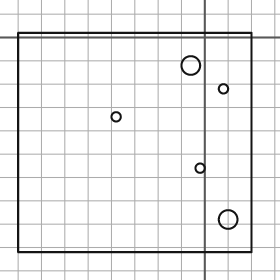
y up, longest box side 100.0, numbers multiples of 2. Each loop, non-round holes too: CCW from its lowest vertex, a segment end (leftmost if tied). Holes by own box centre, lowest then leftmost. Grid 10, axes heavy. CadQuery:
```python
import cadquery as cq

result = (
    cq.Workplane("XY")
    .moveTo(-80.0, -92.0)
    .lineTo(20.0, -92.0)
    .lineTo(20.0, 2.0)
    .lineTo(-80.0, 2.0)
    .close()
    .moveTo(10.0, -78.0)
    .circle(4.0)
    .moveTo(-2.0, -56.0)
    .circle(2.0)
    .moveTo(-38.0, -34.0)
    .circle(2.0)
    .moveTo(8.0, -22.0)
    .circle(2.0)
    .moveTo(-6.0, -12.0)
    .circle(4.0)
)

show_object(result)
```